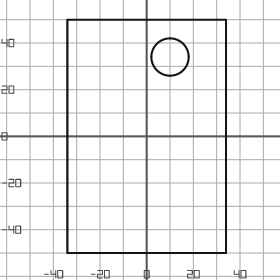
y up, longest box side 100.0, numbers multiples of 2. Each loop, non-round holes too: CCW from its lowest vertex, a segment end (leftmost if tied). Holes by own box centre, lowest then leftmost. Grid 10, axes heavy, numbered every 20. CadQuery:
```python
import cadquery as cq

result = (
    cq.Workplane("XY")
    .moveTo(-34.0, -50.0)
    .lineTo(34.0, -50.0)
    .lineTo(34.0, 50.0)
    .lineTo(-34.0, 50.0)
    .close()
    .moveTo(10.0, 34.0)
    .circle(8.0)
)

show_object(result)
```